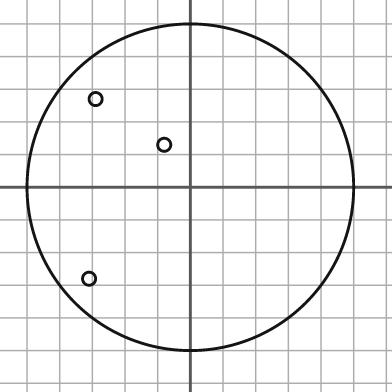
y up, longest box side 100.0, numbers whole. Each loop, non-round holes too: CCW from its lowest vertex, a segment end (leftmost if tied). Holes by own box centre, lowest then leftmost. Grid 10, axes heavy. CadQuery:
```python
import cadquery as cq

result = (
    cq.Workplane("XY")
    .moveTo(0.0, 0.0)
    .circle(50.0)
    .moveTo(-31.0, -28.0)
    .circle(2.0)
    .moveTo(-8.0, 13.0)
    .circle(2.0)
    .moveTo(-29.0, 27.0)
    .circle(2.0)
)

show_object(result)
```